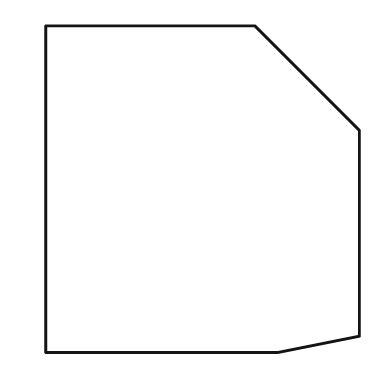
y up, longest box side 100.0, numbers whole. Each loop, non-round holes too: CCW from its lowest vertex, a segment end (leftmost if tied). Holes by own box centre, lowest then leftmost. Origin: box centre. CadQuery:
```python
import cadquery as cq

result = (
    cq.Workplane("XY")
    .moveTo(-48.0, -50.0)
    .lineTo(23.0, -50.0)
    .lineTo(48.0, -45.0)
    .lineTo(48.0, 18.0)
    .lineTo(16.0, 50.0)
    .lineTo(-48.0, 50.0)
    .close()
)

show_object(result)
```